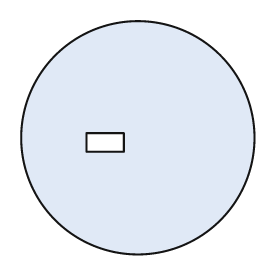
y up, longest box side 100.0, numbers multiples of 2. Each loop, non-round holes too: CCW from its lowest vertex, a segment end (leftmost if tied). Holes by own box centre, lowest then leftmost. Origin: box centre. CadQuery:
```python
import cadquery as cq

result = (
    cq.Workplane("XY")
    .moveTo(0.0, 0.0)
    .circle(50.0)
    .moveTo(-22.0, -6.0)
    .lineTo(-6.0, -6.0)
    .lineTo(-6.0, 2.0)
    .lineTo(-22.0, 2.0)
    .close()
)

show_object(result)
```